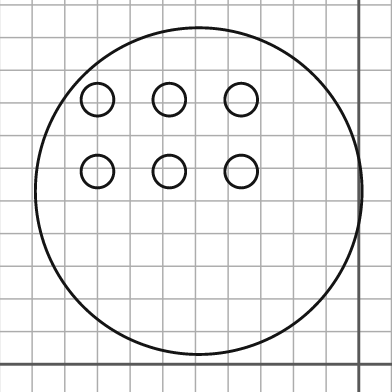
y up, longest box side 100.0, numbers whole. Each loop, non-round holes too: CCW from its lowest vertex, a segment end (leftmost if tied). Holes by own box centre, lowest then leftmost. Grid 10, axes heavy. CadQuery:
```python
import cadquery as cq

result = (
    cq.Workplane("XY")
    .moveTo(-49.0, 53.0)
    .circle(50.0)
    .moveTo(-80.0, 59.0)
    .circle(5.0)
    .moveTo(-58.0, 59.0)
    .circle(5.0)
    .moveTo(-36.0, 59.0)
    .circle(5.0)
    .moveTo(-80.0, 81.0)
    .circle(5.0)
    .moveTo(-58.0, 81.0)
    .circle(5.0)
    .moveTo(-36.0, 81.0)
    .circle(5.0)
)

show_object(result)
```